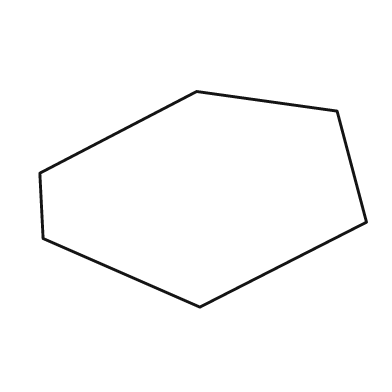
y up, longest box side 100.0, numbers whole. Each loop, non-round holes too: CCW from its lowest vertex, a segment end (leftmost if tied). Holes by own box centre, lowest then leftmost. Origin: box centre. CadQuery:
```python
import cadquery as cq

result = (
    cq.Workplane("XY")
    .moveTo(-1.0, -33.0)
    .lineTo(50.0, -7.0)
    .lineTo(41.0, 27.0)
    .lineTo(-2.0, 33.0)
    .lineTo(-50.0, 8.0)
    .lineTo(-49.0, -12.0)
    .close()
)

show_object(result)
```